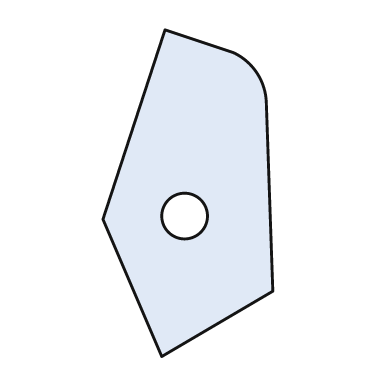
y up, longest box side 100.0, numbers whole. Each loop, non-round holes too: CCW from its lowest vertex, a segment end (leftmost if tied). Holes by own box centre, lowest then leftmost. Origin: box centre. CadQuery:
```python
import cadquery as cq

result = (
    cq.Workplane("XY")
    .moveTo(-8.0, -50.0)
    .lineTo(26.0, -30.0)
    .lineTo(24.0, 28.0)
    .threePointArc((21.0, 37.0), (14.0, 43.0))
    .lineTo(-7.0, 50.0)
    .lineTo(-26.0, -8.0)
    .close()
    .moveTo(-1.0, -7.0)
    .circle(7.0)
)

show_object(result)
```